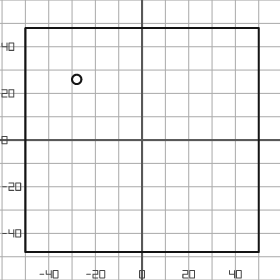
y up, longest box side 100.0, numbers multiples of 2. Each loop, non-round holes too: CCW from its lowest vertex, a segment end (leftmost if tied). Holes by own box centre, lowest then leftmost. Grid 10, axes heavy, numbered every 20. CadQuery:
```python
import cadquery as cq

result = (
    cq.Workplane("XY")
    .moveTo(-50.0, -48.0)
    .lineTo(50.0, -48.0)
    .lineTo(50.0, 48.0)
    .lineTo(-50.0, 48.0)
    .close()
    .moveTo(-28.0, 26.0)
    .circle(2.0)
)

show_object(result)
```